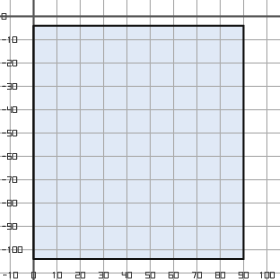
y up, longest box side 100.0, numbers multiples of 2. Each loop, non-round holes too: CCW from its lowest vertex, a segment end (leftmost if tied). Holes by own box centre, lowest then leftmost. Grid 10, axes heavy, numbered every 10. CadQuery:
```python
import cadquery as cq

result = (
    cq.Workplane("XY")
    .moveTo(0.0, -104.0)
    .lineTo(90.0, -104.0)
    .lineTo(90.0, -4.0)
    .lineTo(0.0, -4.0)
    .close()
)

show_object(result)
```